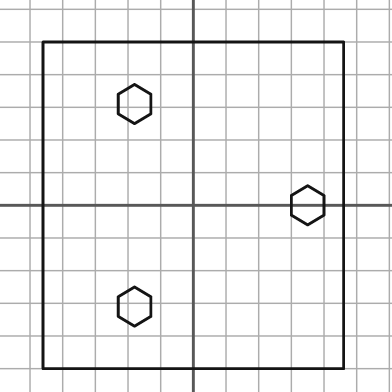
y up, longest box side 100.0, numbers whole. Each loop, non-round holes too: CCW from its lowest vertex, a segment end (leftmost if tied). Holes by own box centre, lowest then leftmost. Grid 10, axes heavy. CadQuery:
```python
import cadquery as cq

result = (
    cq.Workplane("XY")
    .moveTo(-46.0, -50.0)
    .lineTo(46.0, -50.0)
    .lineTo(46.0, 50.0)
    .lineTo(-46.0, 50.0)
    .close()
    .moveTo(-18.0, -37.0)
    .lineTo(-13.0, -34.0)
    .lineTo(-13.0, -28.0)
    .lineTo(-18.0, -25.0)
    .lineTo(-23.0, -28.0)
    .lineTo(-23.0, -34.0)
    .close()
    .moveTo(35.0, -6.0)
    .lineTo(40.0, -3.0)
    .lineTo(40.0, 3.0)
    .lineTo(35.0, 6.0)
    .lineTo(30.0, 3.0)
    .lineTo(30.0, -3.0)
    .close()
    .moveTo(-18.0, 25.0)
    .lineTo(-13.0, 28.0)
    .lineTo(-13.0, 34.0)
    .lineTo(-18.0, 37.0)
    .lineTo(-23.0, 34.0)
    .lineTo(-23.0, 28.0)
    .close()
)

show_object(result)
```